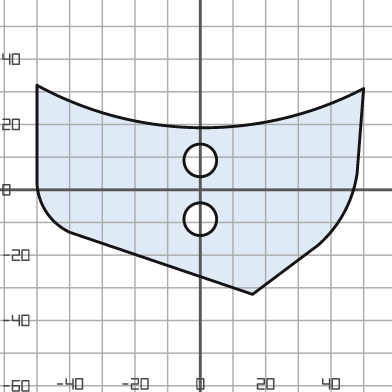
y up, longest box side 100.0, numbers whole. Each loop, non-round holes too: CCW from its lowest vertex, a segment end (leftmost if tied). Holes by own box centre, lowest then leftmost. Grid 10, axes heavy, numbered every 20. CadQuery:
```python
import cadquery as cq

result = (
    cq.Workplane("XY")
    .moveTo(16.0, -32.0)
    .lineTo(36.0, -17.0)
    .threePointArc((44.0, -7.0), (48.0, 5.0))
    .lineTo(50.0, 31.0)
    .threePointArc((0.0, 19.0), (-50.0, 32.0))
    .lineTo(-50.0, 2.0)
    .threePointArc((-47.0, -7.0), (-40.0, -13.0))
    .close()
    .moveTo(0.0, -9.0)
    .circle(5.0)
    .moveTo(0.0, 9.0)
    .circle(5.0)
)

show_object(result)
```